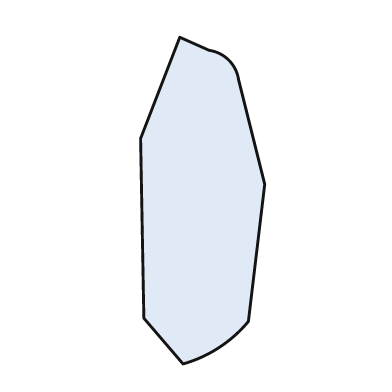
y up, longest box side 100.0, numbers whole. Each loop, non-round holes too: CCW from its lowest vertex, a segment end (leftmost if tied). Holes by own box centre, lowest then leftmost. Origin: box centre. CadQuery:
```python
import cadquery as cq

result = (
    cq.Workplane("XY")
    .moveTo(-6.0, -50.0)
    .threePointArc((5.0, -45.0), (14.0, -37.0))
    .lineTo(19.0, 5.0)
    .lineTo(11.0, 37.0)
    .threePointArc((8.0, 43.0), (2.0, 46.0))
    .lineTo(-7.0, 50.0)
    .lineTo(-19.0, 19.0)
    .lineTo(-18.0, -36.0)
    .close()
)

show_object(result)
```